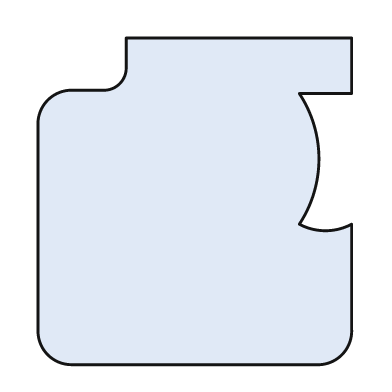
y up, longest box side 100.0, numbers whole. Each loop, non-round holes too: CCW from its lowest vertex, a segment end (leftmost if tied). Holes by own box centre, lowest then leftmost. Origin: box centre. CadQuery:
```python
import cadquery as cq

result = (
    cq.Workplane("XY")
    .moveTo(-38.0, -50.0)
    .lineTo(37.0, -50.0)
    .threePointArc((45.0, -47.0), (48.0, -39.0))
    .lineTo(48.0, -7.0)
    .threePointArc((40.0, -9.0), (32.0, -7.0))
    .threePointArc((38.0, 13.0), (32.0, 33.0))
    .lineTo(48.0, 33.0)
    .lineTo(48.0, 50.0)
    .lineTo(-21.0, 50.0)
    .lineTo(-21.0, 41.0)
    .threePointArc((-23.0, 36.0), (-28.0, 34.0))
    .lineTo(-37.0, 34.0)
    .threePointArc((-45.0, 31.0), (-48.0, 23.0))
    .lineTo(-48.0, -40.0)
    .threePointArc((-45.0, -47.0), (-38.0, -50.0))
    .close()
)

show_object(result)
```